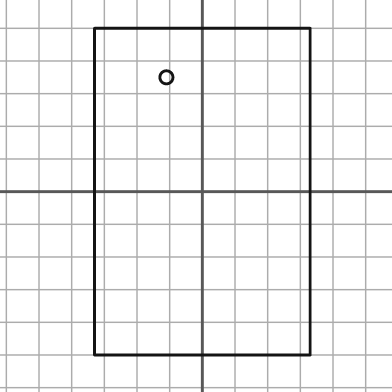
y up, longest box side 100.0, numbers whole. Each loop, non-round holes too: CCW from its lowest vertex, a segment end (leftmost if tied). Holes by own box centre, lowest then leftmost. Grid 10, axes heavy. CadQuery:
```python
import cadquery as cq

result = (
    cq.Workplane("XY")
    .moveTo(-33.0, -50.0)
    .lineTo(33.0, -50.0)
    .lineTo(33.0, 50.0)
    .lineTo(-33.0, 50.0)
    .close()
    .moveTo(-11.0, 35.0)
    .circle(2.0)
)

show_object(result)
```